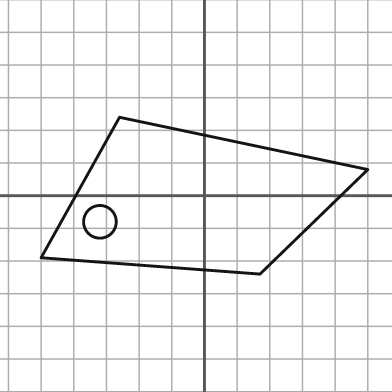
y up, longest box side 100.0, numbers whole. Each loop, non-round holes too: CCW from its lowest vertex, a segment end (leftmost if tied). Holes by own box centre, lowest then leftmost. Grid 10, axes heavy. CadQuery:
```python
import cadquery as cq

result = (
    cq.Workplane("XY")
    .moveTo(17.0, -24.0)
    .lineTo(50.0, 8.0)
    .lineTo(-26.0, 24.0)
    .lineTo(-50.0, -19.0)
    .close()
    .moveTo(-32.0, -8.0)
    .circle(5.0)
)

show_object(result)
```